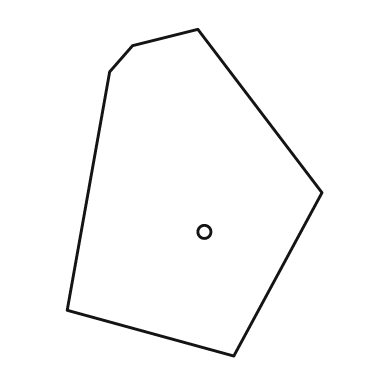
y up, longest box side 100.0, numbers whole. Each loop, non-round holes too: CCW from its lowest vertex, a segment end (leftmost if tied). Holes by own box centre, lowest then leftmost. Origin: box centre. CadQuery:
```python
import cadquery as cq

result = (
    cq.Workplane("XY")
    .moveTo(12.0, -50.0)
    .lineTo(39.0, 0.0)
    .lineTo(1.0, 50.0)
    .lineTo(-19.0, 45.0)
    .lineTo(-26.0, 37.0)
    .lineTo(-39.0, -36.0)
    .close()
    .moveTo(3.0, -12.0)
    .circle(2.0)
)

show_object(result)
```